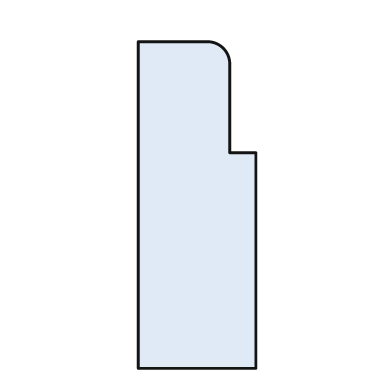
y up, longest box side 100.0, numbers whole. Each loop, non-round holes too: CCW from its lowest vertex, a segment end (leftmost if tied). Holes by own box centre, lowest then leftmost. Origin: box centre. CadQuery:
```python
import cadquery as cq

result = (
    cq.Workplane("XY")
    .moveTo(-18.0, -50.0)
    .lineTo(18.0, -50.0)
    .lineTo(18.0, 16.0)
    .lineTo(10.0, 16.0)
    .lineTo(10.0, 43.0)
    .threePointArc((8.0, 48.0), (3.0, 50.0))
    .lineTo(-18.0, 50.0)
    .close()
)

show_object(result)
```